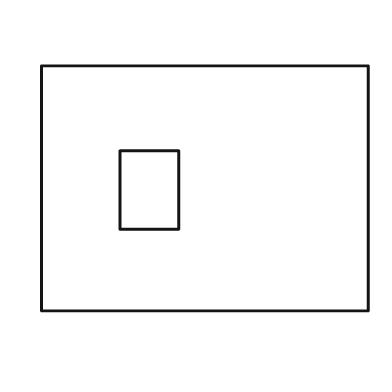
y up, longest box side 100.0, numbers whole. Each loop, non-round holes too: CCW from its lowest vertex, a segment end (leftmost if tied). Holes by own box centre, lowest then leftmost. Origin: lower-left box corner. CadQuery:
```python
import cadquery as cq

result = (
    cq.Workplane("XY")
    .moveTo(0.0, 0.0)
    .lineTo(100.0, 0.0)
    .lineTo(100.0, 75.0)
    .lineTo(0.0, 75.0)
    .close()
    .moveTo(24.0, 25.0)
    .lineTo(42.0, 25.0)
    .lineTo(42.0, 49.0)
    .lineTo(24.0, 49.0)
    .close()
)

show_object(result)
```